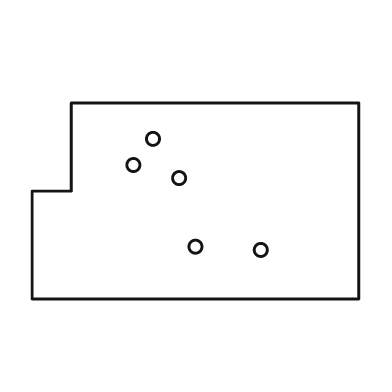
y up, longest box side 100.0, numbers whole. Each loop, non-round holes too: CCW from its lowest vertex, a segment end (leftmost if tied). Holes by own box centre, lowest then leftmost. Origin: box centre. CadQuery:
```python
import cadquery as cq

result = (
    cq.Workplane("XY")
    .moveTo(-50.0, -30.0)
    .lineTo(50.0, -30.0)
    .lineTo(50.0, 30.0)
    .lineTo(-38.0, 30.0)
    .lineTo(-38.0, 3.0)
    .lineTo(-50.0, 3.0)
    .close()
    .moveTo(20.0, -15.0)
    .circle(2.0)
    .moveTo(0.0, -14.0)
    .circle(2.0)
    .moveTo(-5.0, 7.0)
    .circle(2.0)
    .moveTo(-19.0, 11.0)
    .circle(2.0)
    .moveTo(-13.0, 19.0)
    .circle(2.0)
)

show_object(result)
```